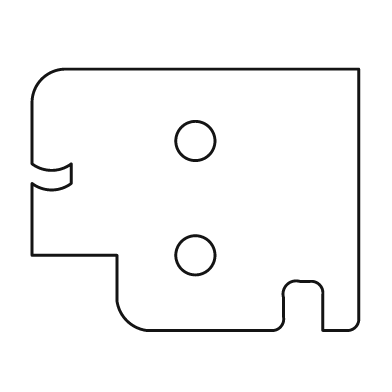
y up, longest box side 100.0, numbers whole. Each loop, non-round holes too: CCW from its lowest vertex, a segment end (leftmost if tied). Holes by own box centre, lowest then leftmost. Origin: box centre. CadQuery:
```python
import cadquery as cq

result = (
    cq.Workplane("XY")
    .moveTo(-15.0, -40.0)
    .lineTo(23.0, -40.0)
    .threePointArc((26.0, -39.0), (27.0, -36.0))
    .lineTo(27.0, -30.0)
    .threePointArc((28.0, -26.0), (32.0, -25.0))
    .lineTo(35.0, -25.0)
    .threePointArc((38.0, -26.0), (39.0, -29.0))
    .lineTo(39.0, -40.0)
    .lineTo(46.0, -40.0)
    .threePointArc((49.0, -39.0), (50.0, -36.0))
    .lineTo(50.0, 40.0)
    .lineTo(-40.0, 40.0)
    .threePointArc((-47.0, 37.0), (-50.0, 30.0))
    .lineTo(-50.0, 11.0)
    .threePointArc((-44.0, 9.0), (-38.0, 11.0))
    .lineTo(-38.0, 5.0)
    .threePointArc((-44.0, 3.0), (-50.0, 5.0))
    .lineTo(-50.0, -17.0)
    .lineTo(-24.0, -17.0)
    .lineTo(-24.0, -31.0)
    .threePointArc((-21.0, -37.0), (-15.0, -40.0))
    .close()
    .moveTo(0.0, -17.0)
    .circle(6.0)
    .moveTo(0.0, 18.0)
    .circle(6.0)
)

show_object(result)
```